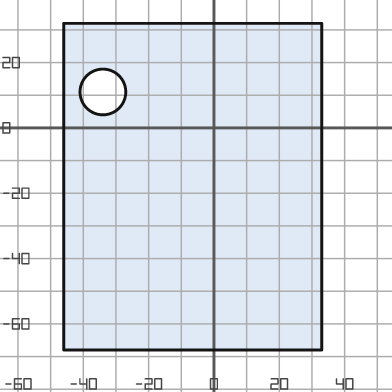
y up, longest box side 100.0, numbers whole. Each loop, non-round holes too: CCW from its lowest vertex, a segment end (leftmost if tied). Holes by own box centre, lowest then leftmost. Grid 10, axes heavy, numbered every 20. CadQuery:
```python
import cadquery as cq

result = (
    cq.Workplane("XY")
    .moveTo(-46.0, -68.0)
    .lineTo(33.0, -68.0)
    .lineTo(33.0, 32.0)
    .lineTo(-46.0, 32.0)
    .close()
    .moveTo(-34.0, 11.0)
    .circle(7.0)
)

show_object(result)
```